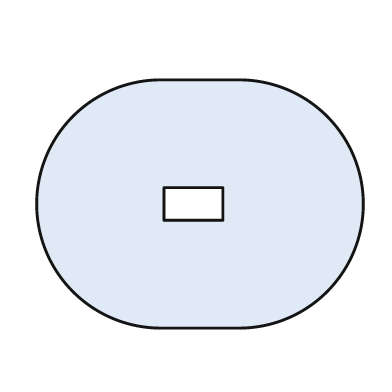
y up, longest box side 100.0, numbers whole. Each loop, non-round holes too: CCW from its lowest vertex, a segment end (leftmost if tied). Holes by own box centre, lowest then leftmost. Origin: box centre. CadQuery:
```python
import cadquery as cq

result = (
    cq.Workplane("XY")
    .moveTo(-12.0, -38.0)
    .lineTo(12.0, -38.0)
    .threePointArc((50.0, 0.0), (12.0, 38.0))
    .lineTo(-12.0, 38.0)
    .threePointArc((-50.0, 0.0), (-12.0, -38.0))
    .close()
    .moveTo(-11.0, -5.0)
    .lineTo(7.0, -5.0)
    .lineTo(7.0, 5.0)
    .lineTo(-11.0, 5.0)
    .close()
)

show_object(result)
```